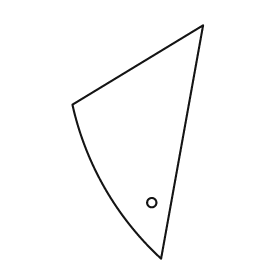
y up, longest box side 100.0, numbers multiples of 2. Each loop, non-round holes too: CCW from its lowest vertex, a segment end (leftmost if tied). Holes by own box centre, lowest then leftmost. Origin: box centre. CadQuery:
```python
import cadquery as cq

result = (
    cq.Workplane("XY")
    .moveTo(10.0, -50.0)
    .lineTo(28.0, 50.0)
    .lineTo(-28.0, 16.0)
    .threePointArc((-14.0, -20.0), (10.0, -50.0))
    .close()
    .moveTo(6.0, -26.0)
    .circle(2.0)
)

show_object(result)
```